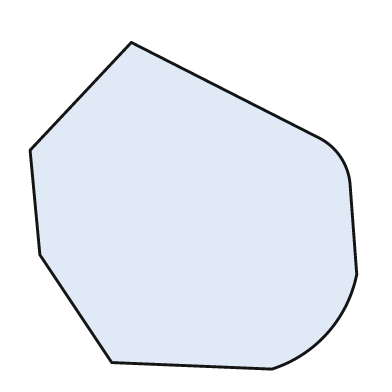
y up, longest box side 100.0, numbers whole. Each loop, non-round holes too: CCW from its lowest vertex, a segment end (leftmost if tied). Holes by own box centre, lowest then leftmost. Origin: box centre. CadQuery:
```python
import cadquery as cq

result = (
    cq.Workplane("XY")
    .moveTo(24.0, -50.0)
    .threePointArc((41.0, -39.0), (50.0, -21.0))
    .lineTo(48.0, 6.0)
    .threePointArc((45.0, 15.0), (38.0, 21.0))
    .lineTo(-19.0, 50.0)
    .lineTo(-50.0, 17.0)
    .lineTo(-47.0, -15.0)
    .lineTo(-25.0, -48.0)
    .close()
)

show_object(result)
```